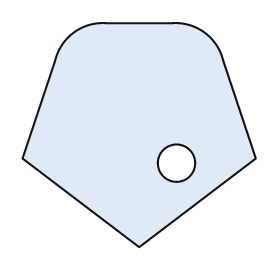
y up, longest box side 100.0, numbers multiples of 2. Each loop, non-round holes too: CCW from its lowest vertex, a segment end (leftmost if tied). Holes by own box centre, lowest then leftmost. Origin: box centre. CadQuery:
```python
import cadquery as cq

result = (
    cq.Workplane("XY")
    .moveTo(0.0, -48.0)
    .lineTo(50.0, -10.0)
    .lineTo(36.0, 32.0)
    .threePointArc((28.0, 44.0), (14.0, 48.0))
    .lineTo(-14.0, 48.0)
    .threePointArc((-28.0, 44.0), (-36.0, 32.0))
    .lineTo(-50.0, -10.0)
    .close()
    .moveTo(16.0, -12.0)
    .circle(8.0)
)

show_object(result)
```